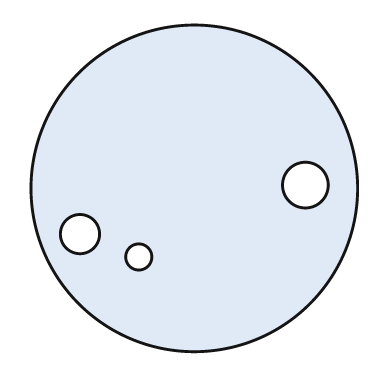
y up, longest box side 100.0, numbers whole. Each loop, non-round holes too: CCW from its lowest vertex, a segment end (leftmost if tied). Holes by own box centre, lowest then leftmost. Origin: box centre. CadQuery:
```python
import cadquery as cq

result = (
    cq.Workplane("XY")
    .moveTo(0.0, 0.0)
    .circle(50.0)
    .moveTo(-17.0, -21.0)
    .circle(4.0)
    .moveTo(-35.0, -14.0)
    .circle(6.0)
    .moveTo(34.0, 1.0)
    .circle(7.0)
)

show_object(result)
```